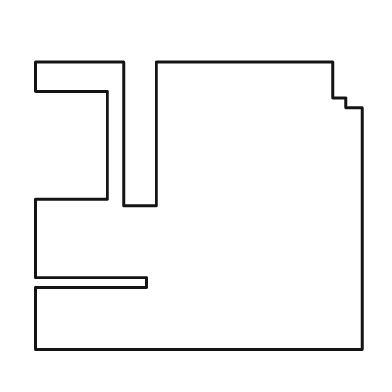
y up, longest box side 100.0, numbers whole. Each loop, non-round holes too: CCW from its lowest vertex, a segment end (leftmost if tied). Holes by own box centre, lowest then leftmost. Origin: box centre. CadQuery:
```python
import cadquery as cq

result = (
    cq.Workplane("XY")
    .moveTo(-50.0, -44.0)
    .lineTo(50.0, -44.0)
    .lineTo(50.0, 30.0)
    .lineTo(45.0, 30.0)
    .lineTo(45.0, 33.0)
    .lineTo(41.0, 33.0)
    .lineTo(41.0, 44.0)
    .lineTo(-13.0, 44.0)
    .lineTo(-13.0, 0.0)
    .lineTo(-23.0, 0.0)
    .lineTo(-23.0, 44.0)
    .lineTo(-50.0, 44.0)
    .lineTo(-50.0, 35.0)
    .lineTo(-28.0, 35.0)
    .lineTo(-28.0, 2.0)
    .lineTo(-50.0, 2.0)
    .lineTo(-50.0, -22.0)
    .lineTo(-16.0, -22.0)
    .lineTo(-16.0, -25.0)
    .lineTo(-50.0, -25.0)
    .close()
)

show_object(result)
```